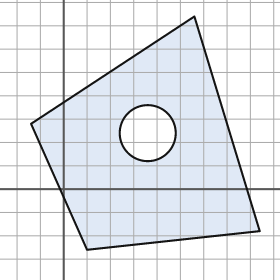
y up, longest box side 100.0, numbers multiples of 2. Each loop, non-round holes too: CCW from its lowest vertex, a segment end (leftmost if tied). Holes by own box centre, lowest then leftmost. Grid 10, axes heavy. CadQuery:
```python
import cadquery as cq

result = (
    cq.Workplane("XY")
    .moveTo(10.0, -26.0)
    .lineTo(84.0, -18.0)
    .lineTo(56.0, 74.0)
    .lineTo(-14.0, 28.0)
    .close()
    .moveTo(36.0, 24.0)
    .circle(12.0)
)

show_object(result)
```